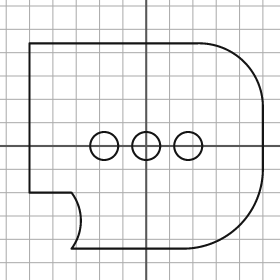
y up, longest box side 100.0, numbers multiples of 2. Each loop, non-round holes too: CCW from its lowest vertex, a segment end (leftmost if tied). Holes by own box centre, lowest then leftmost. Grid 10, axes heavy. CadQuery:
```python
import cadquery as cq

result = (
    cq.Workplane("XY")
    .moveTo(-32.0, -44.0)
    .lineTo(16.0, -44.0)
    .threePointArc((40.0, -34.0), (50.0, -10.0))
    .lineTo(50.0, 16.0)
    .threePointArc((42.0, 36.0), (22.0, 44.0))
    .lineTo(-50.0, 44.0)
    .lineTo(-50.0, -20.0)
    .lineTo(-32.0, -20.0)
    .threePointArc((-28.0, -32.0), (-32.0, -44.0))
    .close()
    .moveTo(-18.0, 0.0)
    .circle(6.0)
    .moveTo(0.0, 0.0)
    .circle(6.0)
    .moveTo(18.0, 0.0)
    .circle(6.0)
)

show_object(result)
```